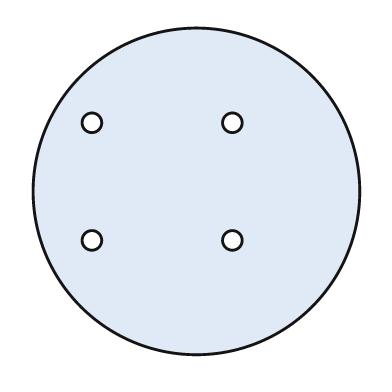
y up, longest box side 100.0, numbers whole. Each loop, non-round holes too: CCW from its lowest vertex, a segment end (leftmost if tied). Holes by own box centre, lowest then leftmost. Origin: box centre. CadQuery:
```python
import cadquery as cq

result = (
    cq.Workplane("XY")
    .moveTo(0.0, 0.0)
    .circle(50.0)
    .moveTo(-32.0, -15.0)
    .circle(3.0)
    .moveTo(11.0, -15.0)
    .circle(3.0)
    .moveTo(-32.0, 21.0)
    .circle(3.0)
    .moveTo(11.0, 21.0)
    .circle(3.0)
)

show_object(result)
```